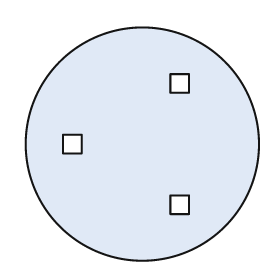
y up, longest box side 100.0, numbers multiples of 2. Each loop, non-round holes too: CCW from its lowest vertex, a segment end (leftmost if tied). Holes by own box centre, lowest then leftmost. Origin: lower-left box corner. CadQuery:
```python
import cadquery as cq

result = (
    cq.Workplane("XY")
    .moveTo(50.0, 50.0)
    .circle(50.0)
    .moveTo(62.0, 20.0)
    .lineTo(70.0, 20.0)
    .lineTo(70.0, 28.0)
    .lineTo(62.0, 28.0)
    .close()
    .moveTo(16.0, 46.0)
    .lineTo(24.0, 46.0)
    .lineTo(24.0, 54.0)
    .lineTo(16.0, 54.0)
    .close()
    .moveTo(62.0, 72.0)
    .lineTo(70.0, 72.0)
    .lineTo(70.0, 80.0)
    .lineTo(62.0, 80.0)
    .close()
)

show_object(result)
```